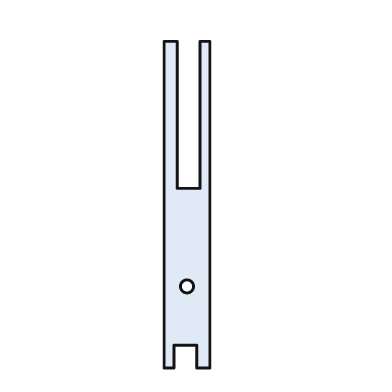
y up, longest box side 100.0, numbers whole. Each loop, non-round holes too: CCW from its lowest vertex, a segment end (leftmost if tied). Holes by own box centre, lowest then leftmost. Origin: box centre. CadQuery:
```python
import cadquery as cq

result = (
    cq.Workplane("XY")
    .moveTo(-7.0, -50.0)
    .lineTo(-4.0, -50.0)
    .lineTo(-4.0, -43.0)
    .lineTo(3.0, -43.0)
    .lineTo(3.0, -50.0)
    .lineTo(7.0, -50.0)
    .lineTo(7.0, 50.0)
    .lineTo(4.0, 50.0)
    .lineTo(4.0, 5.0)
    .lineTo(-3.0, 5.0)
    .lineTo(-3.0, 50.0)
    .lineTo(-7.0, 50.0)
    .close()
    .moveTo(0.0, -25.0)
    .circle(2.0)
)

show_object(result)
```